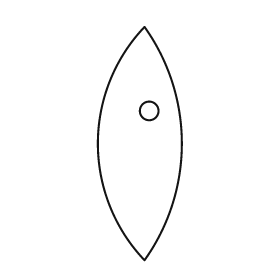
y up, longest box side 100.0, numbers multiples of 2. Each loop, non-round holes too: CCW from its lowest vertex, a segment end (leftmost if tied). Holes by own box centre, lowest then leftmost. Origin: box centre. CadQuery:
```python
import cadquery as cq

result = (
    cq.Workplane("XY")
    .moveTo(2.0, -50.0)
    .threePointArc((18.0, 0.0), (2.0, 50.0))
    .threePointArc((-18.0, 0.0), (2.0, -50.0))
    .close()
    .moveTo(4.0, 14.0)
    .circle(4.0)
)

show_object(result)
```